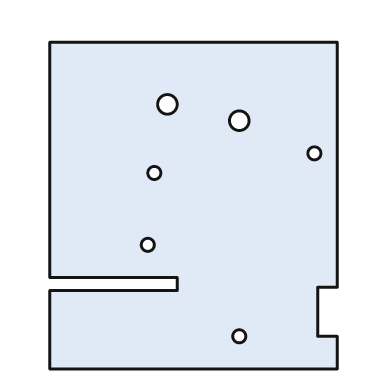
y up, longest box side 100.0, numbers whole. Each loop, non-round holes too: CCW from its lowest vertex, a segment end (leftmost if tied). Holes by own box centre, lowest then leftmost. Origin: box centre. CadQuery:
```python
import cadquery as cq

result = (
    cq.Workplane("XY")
    .moveTo(-44.0, -50.0)
    .lineTo(44.0, -50.0)
    .lineTo(44.0, -40.0)
    .lineTo(38.0, -40.0)
    .lineTo(38.0, -25.0)
    .lineTo(44.0, -25.0)
    .lineTo(44.0, 50.0)
    .lineTo(-44.0, 50.0)
    .lineTo(-44.0, -22.0)
    .lineTo(-5.0, -22.0)
    .lineTo(-5.0, -26.0)
    .lineTo(-44.0, -26.0)
    .close()
    .moveTo(14.0, -40.0)
    .circle(2.0)
    .moveTo(-14.0, -12.0)
    .circle(2.0)
    .moveTo(-12.0, 10.0)
    .circle(2.0)
    .moveTo(37.0, 16.0)
    .circle(2.0)
    .moveTo(14.0, 26.0)
    .circle(3.0)
    .moveTo(-8.0, 31.0)
    .circle(3.0)
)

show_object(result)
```